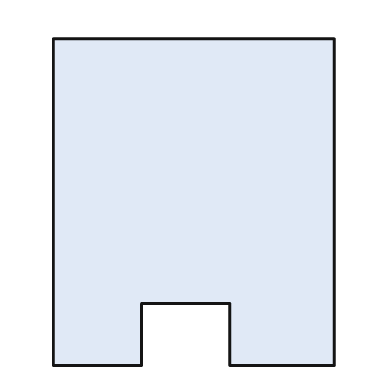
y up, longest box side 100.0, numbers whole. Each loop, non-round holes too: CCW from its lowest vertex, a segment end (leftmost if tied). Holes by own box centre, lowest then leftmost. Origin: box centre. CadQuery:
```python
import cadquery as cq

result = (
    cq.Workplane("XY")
    .moveTo(-43.0, -50.0)
    .lineTo(-16.0, -50.0)
    .lineTo(-16.0, -31.0)
    .lineTo(11.0, -31.0)
    .lineTo(11.0, -50.0)
    .lineTo(43.0, -50.0)
    .lineTo(43.0, 50.0)
    .lineTo(-43.0, 50.0)
    .close()
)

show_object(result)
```